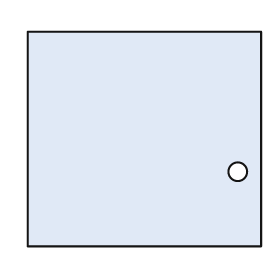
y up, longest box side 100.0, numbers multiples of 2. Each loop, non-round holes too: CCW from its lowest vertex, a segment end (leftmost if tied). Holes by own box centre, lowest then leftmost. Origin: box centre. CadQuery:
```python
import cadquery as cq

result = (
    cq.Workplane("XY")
    .moveTo(-50.0, -46.0)
    .lineTo(50.0, -46.0)
    .lineTo(50.0, 46.0)
    .lineTo(-50.0, 46.0)
    .close()
    .moveTo(40.0, -14.0)
    .circle(4.0)
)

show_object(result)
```